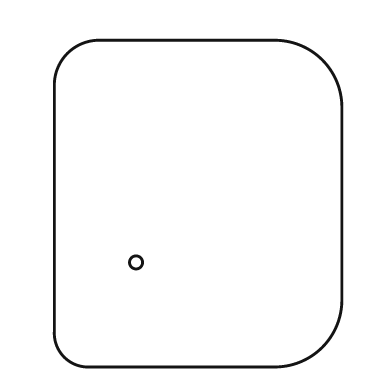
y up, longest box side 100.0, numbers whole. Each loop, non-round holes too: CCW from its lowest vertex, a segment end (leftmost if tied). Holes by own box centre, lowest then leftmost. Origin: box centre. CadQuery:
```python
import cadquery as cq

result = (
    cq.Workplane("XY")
    .moveTo(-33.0, -50.0)
    .lineTo(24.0, -50.0)
    .threePointArc((38.0, -44.0), (44.0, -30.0))
    .lineTo(44.0, 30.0)
    .threePointArc((38.0, 44.0), (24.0, 50.0))
    .lineTo(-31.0, 50.0)
    .threePointArc((-40.0, 46.0), (-44.0, 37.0))
    .lineTo(-44.0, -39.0)
    .threePointArc((-41.0, -47.0), (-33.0, -50.0))
    .close()
    .moveTo(-19.0, -18.0)
    .circle(2.0)
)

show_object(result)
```